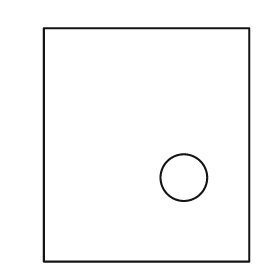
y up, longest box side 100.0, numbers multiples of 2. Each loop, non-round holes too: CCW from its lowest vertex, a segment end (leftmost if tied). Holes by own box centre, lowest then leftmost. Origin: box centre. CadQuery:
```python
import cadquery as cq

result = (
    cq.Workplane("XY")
    .moveTo(-44.0, -50.0)
    .lineTo(44.0, -50.0)
    .lineTo(44.0, 50.0)
    .lineTo(-44.0, 50.0)
    .close()
    .moveTo(16.0, -14.0)
    .circle(10.0)
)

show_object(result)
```